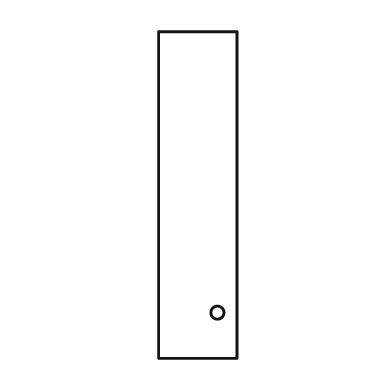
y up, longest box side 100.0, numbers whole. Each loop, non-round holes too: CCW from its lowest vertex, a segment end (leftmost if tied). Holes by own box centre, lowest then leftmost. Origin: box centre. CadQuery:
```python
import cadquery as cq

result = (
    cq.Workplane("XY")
    .moveTo(-12.0, -50.0)
    .lineTo(12.0, -50.0)
    .lineTo(12.0, 50.0)
    .lineTo(-12.0, 50.0)
    .close()
    .moveTo(6.0, -36.0)
    .circle(2.0)
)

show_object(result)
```